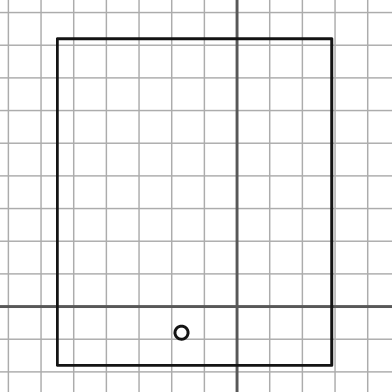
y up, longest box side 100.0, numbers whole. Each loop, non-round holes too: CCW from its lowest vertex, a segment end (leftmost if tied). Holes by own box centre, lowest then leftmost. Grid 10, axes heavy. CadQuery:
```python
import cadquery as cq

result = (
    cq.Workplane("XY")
    .moveTo(-55.0, -18.0)
    .lineTo(29.0, -18.0)
    .lineTo(29.0, 82.0)
    .lineTo(-55.0, 82.0)
    .close()
    .moveTo(-17.0, -8.0)
    .circle(2.0)
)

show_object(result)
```